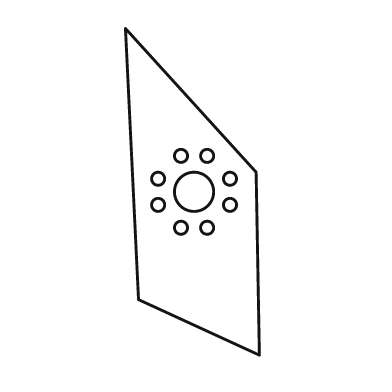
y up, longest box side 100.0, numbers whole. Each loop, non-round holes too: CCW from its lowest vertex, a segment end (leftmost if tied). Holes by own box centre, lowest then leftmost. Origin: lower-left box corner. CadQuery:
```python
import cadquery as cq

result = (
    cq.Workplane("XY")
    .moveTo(41.0, 0.0)
    .lineTo(40.0, 56.0)
    .lineTo(0.0, 100.0)
    .lineTo(4.0, 17.0)
    .close()
    .moveTo(17.0, 39.0)
    .circle(2.0)
    .moveTo(25.0, 39.0)
    .circle(2.0)
    .moveTo(10.0, 46.0)
    .circle(2.0)
    .moveTo(32.0, 46.0)
    .circle(2.0)
    .moveTo(21.0, 50.0)
    .circle(6.0)
    .moveTo(10.0, 54.0)
    .circle(2.0)
    .moveTo(32.0, 54.0)
    .circle(2.0)
    .moveTo(17.0, 61.0)
    .circle(2.0)
    .moveTo(25.0, 61.0)
    .circle(2.0)
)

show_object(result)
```